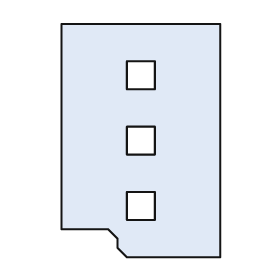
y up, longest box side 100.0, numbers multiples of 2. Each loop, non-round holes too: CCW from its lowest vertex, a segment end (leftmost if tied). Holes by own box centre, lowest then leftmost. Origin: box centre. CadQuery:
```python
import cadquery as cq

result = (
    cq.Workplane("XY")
    .moveTo(-6.0, -50.0)
    .lineTo(34.0, -50.0)
    .lineTo(34.0, 50.0)
    .lineTo(-34.0, 50.0)
    .lineTo(-34.0, -38.0)
    .lineTo(-14.0, -38.0)
    .lineTo(-10.0, -42.0)
    .lineTo(-10.0, -46.0)
    .close()
    .moveTo(-6.0, -34.0)
    .lineTo(6.0, -34.0)
    .lineTo(6.0, -22.0)
    .lineTo(-6.0, -22.0)
    .close()
    .moveTo(-6.0, -6.0)
    .lineTo(6.0, -6.0)
    .lineTo(6.0, 6.0)
    .lineTo(-6.0, 6.0)
    .close()
    .moveTo(-6.0, 22.0)
    .lineTo(6.0, 22.0)
    .lineTo(6.0, 34.0)
    .lineTo(-6.0, 34.0)
    .close()
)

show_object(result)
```